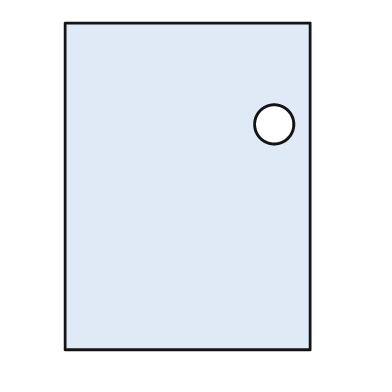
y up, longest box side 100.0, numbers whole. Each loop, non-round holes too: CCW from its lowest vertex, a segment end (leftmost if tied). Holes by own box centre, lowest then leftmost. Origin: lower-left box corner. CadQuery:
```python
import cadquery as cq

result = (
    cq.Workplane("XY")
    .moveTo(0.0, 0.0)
    .lineTo(75.0, 0.0)
    .lineTo(75.0, 100.0)
    .lineTo(0.0, 100.0)
    .close()
    .moveTo(64.0, 69.0)
    .circle(6.0)
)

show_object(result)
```